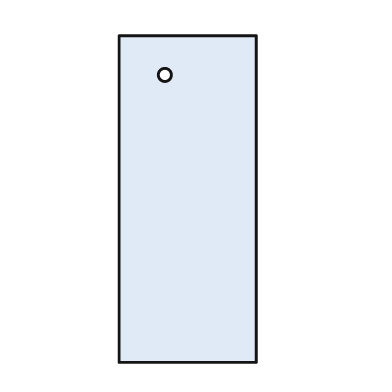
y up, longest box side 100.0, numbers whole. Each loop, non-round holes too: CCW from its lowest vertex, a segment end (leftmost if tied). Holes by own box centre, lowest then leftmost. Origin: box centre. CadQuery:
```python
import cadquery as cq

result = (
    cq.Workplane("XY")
    .moveTo(-21.0, -50.0)
    .lineTo(21.0, -50.0)
    .lineTo(21.0, 50.0)
    .lineTo(-21.0, 50.0)
    .close()
    .moveTo(-7.0, 38.0)
    .circle(2.0)
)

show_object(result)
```